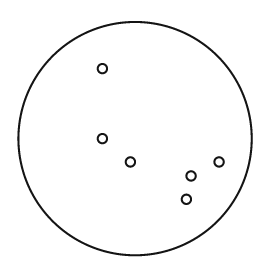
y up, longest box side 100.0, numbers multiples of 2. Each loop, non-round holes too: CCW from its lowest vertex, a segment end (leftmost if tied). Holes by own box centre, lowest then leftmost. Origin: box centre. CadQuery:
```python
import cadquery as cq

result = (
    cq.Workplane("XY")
    .moveTo(0.0, 0.0)
    .circle(50.0)
    .moveTo(22.0, -26.0)
    .circle(2.0)
    .moveTo(24.0, -16.0)
    .circle(2.0)
    .moveTo(-2.0, -10.0)
    .circle(2.0)
    .moveTo(36.0, -10.0)
    .circle(2.0)
    .moveTo(-14.0, 0.0)
    .circle(2.0)
    .moveTo(-14.0, 30.0)
    .circle(2.0)
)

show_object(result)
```